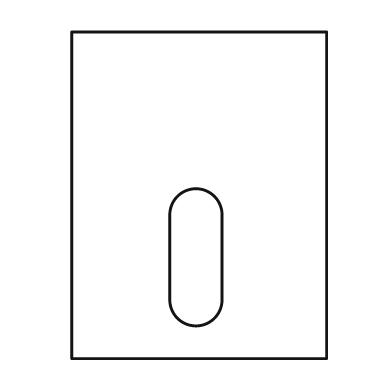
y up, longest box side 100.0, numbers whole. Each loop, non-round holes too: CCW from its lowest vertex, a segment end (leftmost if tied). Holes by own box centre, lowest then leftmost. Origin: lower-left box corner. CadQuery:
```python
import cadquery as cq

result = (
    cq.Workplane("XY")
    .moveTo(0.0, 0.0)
    .lineTo(78.0, 0.0)
    .lineTo(78.0, 100.0)
    .lineTo(0.0, 100.0)
    .close()
    .moveTo(30.0, 18.0)
    .threePointArc((38.0, 10.0), (46.0, 18.0))
    .lineTo(46.0, 44.0)
    .threePointArc((38.0, 52.0), (30.0, 44.0))
    .close()
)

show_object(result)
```